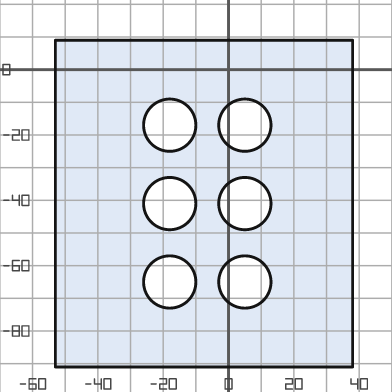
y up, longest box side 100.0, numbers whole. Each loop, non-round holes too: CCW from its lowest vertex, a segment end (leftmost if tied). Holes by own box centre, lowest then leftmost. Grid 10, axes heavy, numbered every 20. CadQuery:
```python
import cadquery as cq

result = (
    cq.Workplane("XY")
    .moveTo(-53.0, -91.0)
    .lineTo(38.0, -91.0)
    .lineTo(38.0, 9.0)
    .lineTo(-53.0, 9.0)
    .close()
    .moveTo(-18.0, -65.0)
    .circle(8.0)
    .moveTo(5.0, -65.0)
    .circle(8.0)
    .moveTo(-18.0, -41.0)
    .circle(8.0)
    .moveTo(5.0, -41.0)
    .circle(8.0)
    .moveTo(-18.0, -17.0)
    .circle(8.0)
    .moveTo(5.0, -17.0)
    .circle(8.0)
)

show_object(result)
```